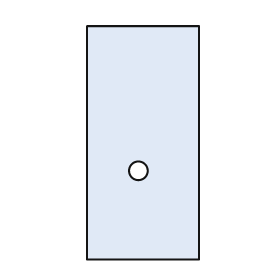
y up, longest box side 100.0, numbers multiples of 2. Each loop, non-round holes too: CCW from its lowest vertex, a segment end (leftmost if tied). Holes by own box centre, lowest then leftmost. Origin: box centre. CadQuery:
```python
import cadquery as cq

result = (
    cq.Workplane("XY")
    .moveTo(-24.0, -50.0)
    .lineTo(24.0, -50.0)
    .lineTo(24.0, 50.0)
    .lineTo(-24.0, 50.0)
    .close()
    .moveTo(-2.0, -12.0)
    .circle(4.0)
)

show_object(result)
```